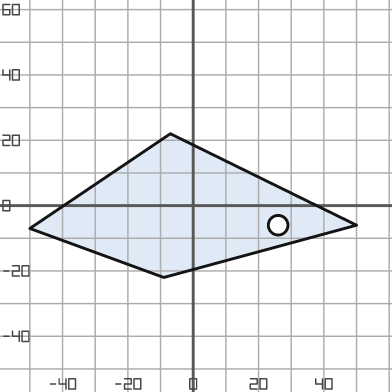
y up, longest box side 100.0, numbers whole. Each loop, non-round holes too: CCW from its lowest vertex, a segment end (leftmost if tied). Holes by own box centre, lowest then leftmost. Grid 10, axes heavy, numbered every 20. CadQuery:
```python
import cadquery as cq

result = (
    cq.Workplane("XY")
    .moveTo(-9.0, -22.0)
    .lineTo(50.0, -6.0)
    .lineTo(-7.0, 22.0)
    .lineTo(-50.0, -7.0)
    .close()
    .moveTo(26.0, -6.0)
    .circle(3.0)
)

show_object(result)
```